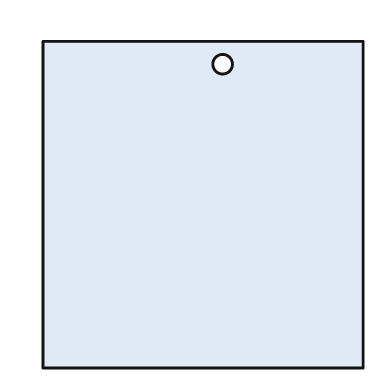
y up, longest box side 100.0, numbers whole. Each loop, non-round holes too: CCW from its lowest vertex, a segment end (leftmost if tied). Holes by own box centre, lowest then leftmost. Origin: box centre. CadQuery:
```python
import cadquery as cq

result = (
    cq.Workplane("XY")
    .moveTo(-49.0, -50.0)
    .lineTo(49.0, -50.0)
    .lineTo(49.0, 50.0)
    .lineTo(-49.0, 50.0)
    .close()
    .moveTo(6.0, 43.0)
    .circle(3.0)
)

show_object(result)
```